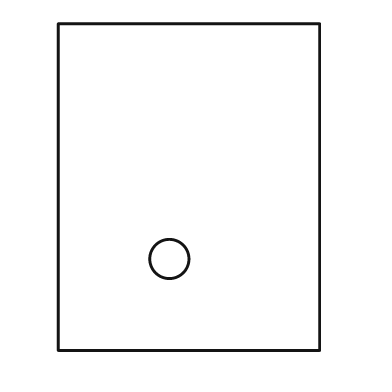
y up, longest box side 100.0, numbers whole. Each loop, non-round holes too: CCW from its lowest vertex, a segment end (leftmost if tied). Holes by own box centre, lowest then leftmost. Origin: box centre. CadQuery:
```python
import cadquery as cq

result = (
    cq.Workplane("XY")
    .moveTo(-40.0, -50.0)
    .lineTo(40.0, -50.0)
    .lineTo(40.0, 50.0)
    .lineTo(-40.0, 50.0)
    .close()
    .moveTo(-6.0, -22.0)
    .circle(6.0)
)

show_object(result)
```